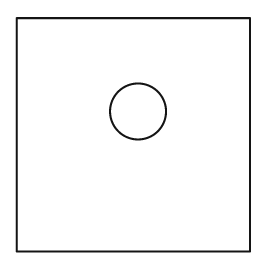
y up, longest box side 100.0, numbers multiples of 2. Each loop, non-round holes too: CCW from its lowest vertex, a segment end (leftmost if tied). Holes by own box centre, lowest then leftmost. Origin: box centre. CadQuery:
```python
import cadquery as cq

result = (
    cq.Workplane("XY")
    .moveTo(-50.0, -50.0)
    .lineTo(50.0, -50.0)
    .lineTo(50.0, 50.0)
    .lineTo(-50.0, 50.0)
    .close()
    .moveTo(2.0, 10.0)
    .circle(12.0)
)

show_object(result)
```